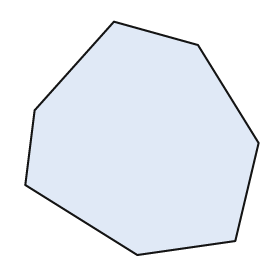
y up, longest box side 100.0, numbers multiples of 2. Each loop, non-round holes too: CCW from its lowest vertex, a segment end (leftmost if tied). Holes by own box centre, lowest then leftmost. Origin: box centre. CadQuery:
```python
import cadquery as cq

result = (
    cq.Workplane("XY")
    .moveTo(-2.0, -50.0)
    .lineTo(40.0, -44.0)
    .lineTo(50.0, -2.0)
    .lineTo(24.0, 40.0)
    .lineTo(-12.0, 50.0)
    .lineTo(-46.0, 12.0)
    .lineTo(-50.0, -20.0)
    .close()
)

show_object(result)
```